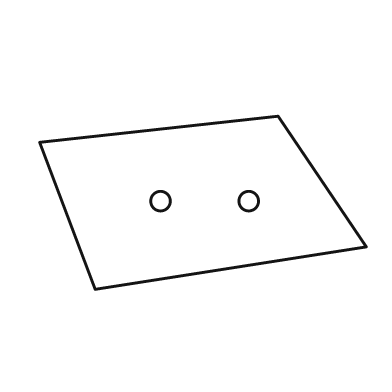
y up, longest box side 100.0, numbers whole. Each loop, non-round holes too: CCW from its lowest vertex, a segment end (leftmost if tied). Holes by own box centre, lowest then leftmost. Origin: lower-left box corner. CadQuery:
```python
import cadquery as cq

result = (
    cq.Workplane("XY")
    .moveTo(17.0, 0.0)
    .lineTo(100.0, 13.0)
    .lineTo(73.0, 53.0)
    .lineTo(0.0, 45.0)
    .close()
    .moveTo(37.0, 27.0)
    .circle(3.0)
    .moveTo(64.0, 27.0)
    .circle(3.0)
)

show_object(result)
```